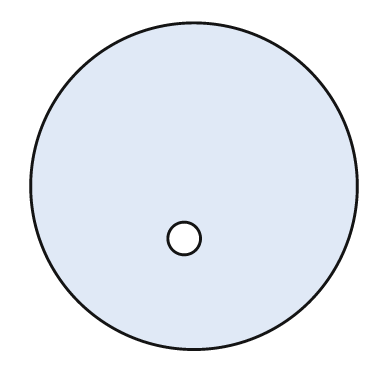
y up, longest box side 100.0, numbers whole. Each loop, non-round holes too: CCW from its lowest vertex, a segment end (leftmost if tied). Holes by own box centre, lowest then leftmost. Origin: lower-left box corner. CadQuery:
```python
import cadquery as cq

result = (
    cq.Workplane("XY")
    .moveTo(50.0, 50.0)
    .circle(50.0)
    .moveTo(47.0, 34.0)
    .circle(5.0)
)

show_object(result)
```